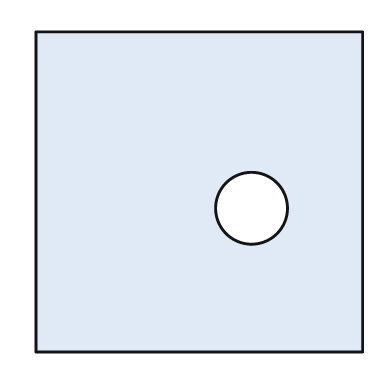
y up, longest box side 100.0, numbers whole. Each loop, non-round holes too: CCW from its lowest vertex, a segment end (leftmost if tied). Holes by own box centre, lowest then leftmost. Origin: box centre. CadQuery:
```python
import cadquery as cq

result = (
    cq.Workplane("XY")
    .moveTo(-50.0, -49.0)
    .lineTo(50.0, -49.0)
    .lineTo(50.0, 49.0)
    .lineTo(-50.0, 49.0)
    .close()
    .moveTo(16.0, -5.0)
    .circle(11.0)
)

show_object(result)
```